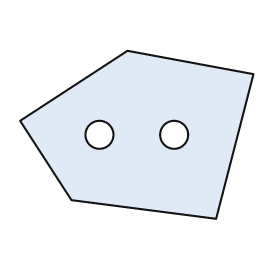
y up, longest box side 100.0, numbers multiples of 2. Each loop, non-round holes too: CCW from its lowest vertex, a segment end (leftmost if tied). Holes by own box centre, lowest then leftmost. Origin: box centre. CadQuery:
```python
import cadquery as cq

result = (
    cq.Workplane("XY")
    .moveTo(34.0, -36.0)
    .lineTo(50.0, 26.0)
    .lineTo(-4.0, 36.0)
    .lineTo(-50.0, 6.0)
    .lineTo(-28.0, -28.0)
    .close()
    .moveTo(-16.0, 0.0)
    .circle(6.0)
    .moveTo(16.0, 0.0)
    .circle(6.0)
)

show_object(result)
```